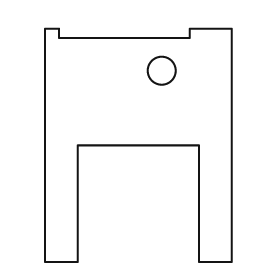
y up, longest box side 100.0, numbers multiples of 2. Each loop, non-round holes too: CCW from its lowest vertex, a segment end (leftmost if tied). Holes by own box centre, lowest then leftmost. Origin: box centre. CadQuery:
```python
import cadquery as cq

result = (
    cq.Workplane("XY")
    .moveTo(-40.0, -50.0)
    .lineTo(-26.0, -50.0)
    .lineTo(-26.0, 0.0)
    .lineTo(26.0, 0.0)
    .lineTo(26.0, -50.0)
    .lineTo(40.0, -50.0)
    .lineTo(40.0, 50.0)
    .lineTo(22.0, 50.0)
    .lineTo(22.0, 46.0)
    .lineTo(-34.0, 46.0)
    .lineTo(-34.0, 50.0)
    .lineTo(-40.0, 50.0)
    .close()
    .moveTo(10.0, 32.0)
    .circle(6.0)
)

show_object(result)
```